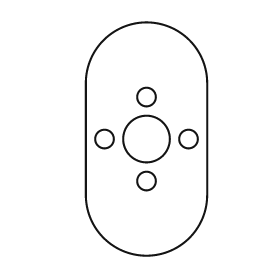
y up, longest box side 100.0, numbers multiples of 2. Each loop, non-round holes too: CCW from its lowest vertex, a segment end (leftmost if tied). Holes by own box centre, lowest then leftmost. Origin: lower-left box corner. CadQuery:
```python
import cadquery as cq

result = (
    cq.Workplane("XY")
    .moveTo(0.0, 26.0)
    .threePointArc((26.0, 0.0), (52.0, 26.0))
    .lineTo(52.0, 74.0)
    .threePointArc((26.0, 100.0), (0.0, 74.0))
    .close()
    .moveTo(26.0, 32.0)
    .circle(4.0)
    .moveTo(8.0, 50.0)
    .circle(4.0)
    .moveTo(26.0, 50.0)
    .circle(10.0)
    .moveTo(44.0, 50.0)
    .circle(4.0)
    .moveTo(26.0, 68.0)
    .circle(4.0)
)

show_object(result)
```